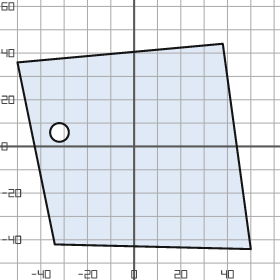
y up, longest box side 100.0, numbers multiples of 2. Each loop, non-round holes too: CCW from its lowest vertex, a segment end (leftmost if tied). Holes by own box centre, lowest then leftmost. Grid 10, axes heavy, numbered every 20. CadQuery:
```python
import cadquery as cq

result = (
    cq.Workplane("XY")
    .moveTo(50.0, -44.0)
    .lineTo(38.0, 44.0)
    .lineTo(-50.0, 36.0)
    .lineTo(-34.0, -42.0)
    .close()
    .moveTo(-32.0, 6.0)
    .circle(4.0)
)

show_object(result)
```